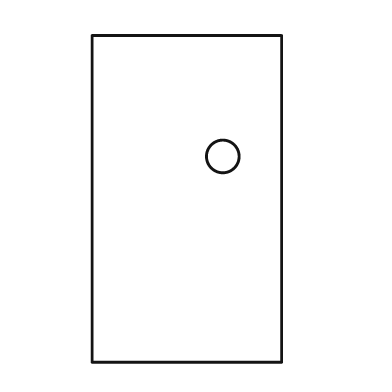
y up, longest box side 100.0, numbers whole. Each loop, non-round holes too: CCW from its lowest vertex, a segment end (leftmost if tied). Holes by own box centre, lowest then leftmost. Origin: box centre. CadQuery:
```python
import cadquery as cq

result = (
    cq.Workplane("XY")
    .moveTo(-29.0, -50.0)
    .lineTo(29.0, -50.0)
    .lineTo(29.0, 50.0)
    .lineTo(-29.0, 50.0)
    .close()
    .moveTo(11.0, 13.0)
    .circle(5.0)
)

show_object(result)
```